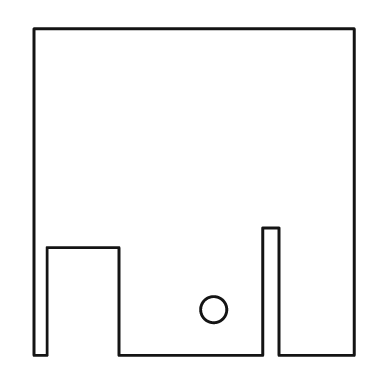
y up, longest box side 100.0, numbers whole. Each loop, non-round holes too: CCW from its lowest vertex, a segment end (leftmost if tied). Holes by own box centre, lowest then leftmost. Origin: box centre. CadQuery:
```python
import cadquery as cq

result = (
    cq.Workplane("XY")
    .moveTo(-49.0, -50.0)
    .lineTo(-45.0, -50.0)
    .lineTo(-45.0, -17.0)
    .lineTo(-23.0, -17.0)
    .lineTo(-23.0, -50.0)
    .lineTo(21.0, -50.0)
    .lineTo(21.0, -11.0)
    .lineTo(26.0, -11.0)
    .lineTo(26.0, -50.0)
    .lineTo(49.0, -50.0)
    .lineTo(49.0, 50.0)
    .lineTo(-49.0, 50.0)
    .close()
    .moveTo(6.0, -36.0)
    .circle(4.0)
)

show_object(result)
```